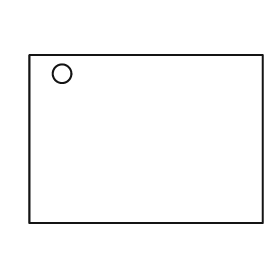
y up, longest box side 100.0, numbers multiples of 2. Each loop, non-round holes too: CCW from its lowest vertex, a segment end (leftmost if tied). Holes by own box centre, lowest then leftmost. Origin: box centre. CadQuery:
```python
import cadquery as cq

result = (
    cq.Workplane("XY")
    .moveTo(-50.0, -36.0)
    .lineTo(50.0, -36.0)
    .lineTo(50.0, 36.0)
    .lineTo(-50.0, 36.0)
    .close()
    .moveTo(-36.0, 28.0)
    .circle(4.0)
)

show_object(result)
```